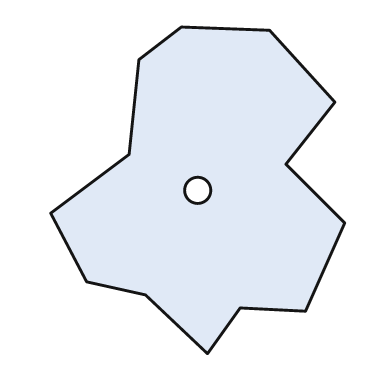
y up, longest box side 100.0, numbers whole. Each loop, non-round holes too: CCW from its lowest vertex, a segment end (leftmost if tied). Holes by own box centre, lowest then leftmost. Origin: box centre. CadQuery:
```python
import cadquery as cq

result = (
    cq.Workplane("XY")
    .moveTo(3.0, -50.0)
    .lineTo(13.0, -36.0)
    .lineTo(33.0, -37.0)
    .lineTo(45.0, -10.0)
    .lineTo(27.0, 8.0)
    .lineTo(42.0, 27.0)
    .lineTo(22.0, 49.0)
    .lineTo(-5.0, 50.0)
    .lineTo(-18.0, 40.0)
    .lineTo(-21.0, 11.0)
    .lineTo(-45.0, -7.0)
    .lineTo(-34.0, -28.0)
    .lineTo(-16.0, -32.0)
    .close()
    .moveTo(0.0, 0.0)
    .circle(4.0)
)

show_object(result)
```